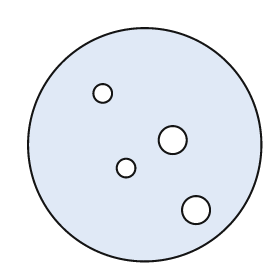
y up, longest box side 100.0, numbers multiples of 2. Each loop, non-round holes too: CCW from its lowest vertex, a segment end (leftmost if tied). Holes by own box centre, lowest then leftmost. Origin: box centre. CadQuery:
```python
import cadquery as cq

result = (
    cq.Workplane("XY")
    .moveTo(0.0, 0.0)
    .circle(50.0)
    .moveTo(22.0, -28.0)
    .circle(6.0)
    .moveTo(-8.0, -10.0)
    .circle(4.0)
    .moveTo(12.0, 2.0)
    .circle(6.0)
    .moveTo(-18.0, 22.0)
    .circle(4.0)
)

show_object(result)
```